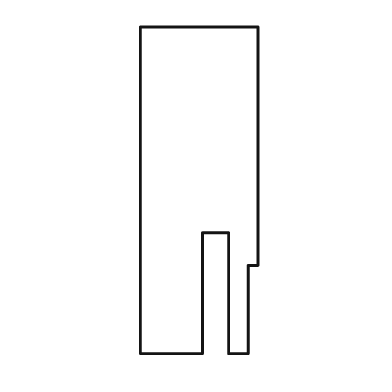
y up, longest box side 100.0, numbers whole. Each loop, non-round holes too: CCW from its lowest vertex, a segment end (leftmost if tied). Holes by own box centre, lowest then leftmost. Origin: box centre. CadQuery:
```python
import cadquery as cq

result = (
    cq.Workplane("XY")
    .moveTo(-18.0, -50.0)
    .lineTo(1.0, -50.0)
    .lineTo(1.0, -13.0)
    .lineTo(9.0, -13.0)
    .lineTo(9.0, -50.0)
    .lineTo(15.0, -50.0)
    .lineTo(15.0, -23.0)
    .lineTo(18.0, -23.0)
    .lineTo(18.0, 50.0)
    .lineTo(-18.0, 50.0)
    .close()
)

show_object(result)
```